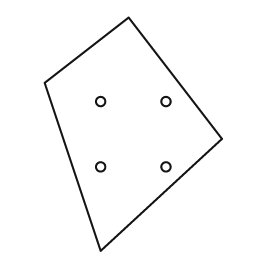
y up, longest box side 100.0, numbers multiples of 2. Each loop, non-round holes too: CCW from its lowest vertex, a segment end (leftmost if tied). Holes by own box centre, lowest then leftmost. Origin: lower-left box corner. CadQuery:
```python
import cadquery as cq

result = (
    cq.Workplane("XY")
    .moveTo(24.0, 0.0)
    .lineTo(76.0, 48.0)
    .lineTo(36.0, 100.0)
    .lineTo(0.0, 72.0)
    .close()
    .moveTo(24.0, 36.0)
    .circle(2.0)
    .moveTo(52.0, 36.0)
    .circle(2.0)
    .moveTo(24.0, 64.0)
    .circle(2.0)
    .moveTo(52.0, 64.0)
    .circle(2.0)
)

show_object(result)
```